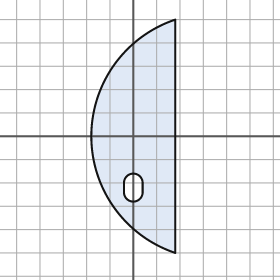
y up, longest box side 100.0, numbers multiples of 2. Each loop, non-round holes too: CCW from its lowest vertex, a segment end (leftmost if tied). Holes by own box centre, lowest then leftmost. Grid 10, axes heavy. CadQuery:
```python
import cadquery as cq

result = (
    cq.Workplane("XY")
    .moveTo(18.0, -50.0)
    .lineTo(18.0, 50.0)
    .threePointArc((-18.0, 0.0), (18.0, -50.0))
    .close()
    .moveTo(-4.0, -24.0)
    .threePointArc((0.0, -28.0), (4.0, -24.0))
    .lineTo(4.0, -20.0)
    .threePointArc((0.0, -16.0), (-4.0, -20.0))
    .close()
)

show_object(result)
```